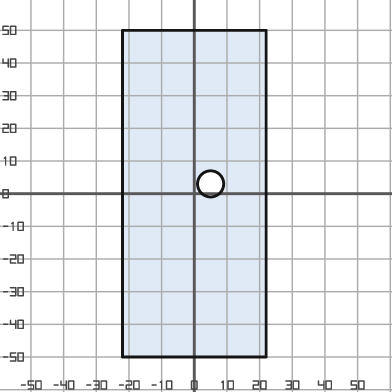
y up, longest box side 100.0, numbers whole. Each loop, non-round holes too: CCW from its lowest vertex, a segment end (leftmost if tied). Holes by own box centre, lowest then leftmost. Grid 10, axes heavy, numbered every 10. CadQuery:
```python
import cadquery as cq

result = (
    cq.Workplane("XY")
    .moveTo(-22.0, -50.0)
    .lineTo(22.0, -50.0)
    .lineTo(22.0, 50.0)
    .lineTo(-22.0, 50.0)
    .close()
    .moveTo(5.0, 3.0)
    .circle(4.0)
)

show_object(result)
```